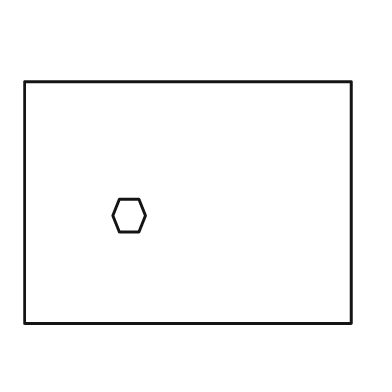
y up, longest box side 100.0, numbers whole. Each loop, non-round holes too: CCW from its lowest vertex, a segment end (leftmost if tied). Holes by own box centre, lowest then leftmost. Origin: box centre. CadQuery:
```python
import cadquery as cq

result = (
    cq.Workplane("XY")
    .moveTo(-50.0, -37.0)
    .lineTo(50.0, -37.0)
    .lineTo(50.0, 37.0)
    .lineTo(-50.0, 37.0)
    .close()
    .moveTo(-21.0, -9.0)
    .lineTo(-15.0, -9.0)
    .lineTo(-13.0, -4.0)
    .lineTo(-15.0, 1.0)
    .lineTo(-21.0, 1.0)
    .lineTo(-23.0, -4.0)
    .close()
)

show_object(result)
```